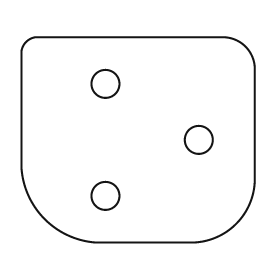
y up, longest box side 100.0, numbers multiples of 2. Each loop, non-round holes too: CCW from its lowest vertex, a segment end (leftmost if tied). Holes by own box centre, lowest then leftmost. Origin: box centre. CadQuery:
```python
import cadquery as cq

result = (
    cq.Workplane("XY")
    .moveTo(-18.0, -44.0)
    .lineTo(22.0, -44.0)
    .threePointArc((42.0, -36.0), (50.0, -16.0))
    .lineTo(50.0, 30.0)
    .threePointArc((46.0, 40.0), (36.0, 44.0))
    .lineTo(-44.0, 44.0)
    .threePointArc((-48.0, 42.0), (-50.0, 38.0))
    .lineTo(-50.0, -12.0)
    .threePointArc((-40.0, -34.0), (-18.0, -44.0))
    .close()
    .moveTo(-14.0, -24.0)
    .circle(6.0)
    .moveTo(26.0, 0.0)
    .circle(6.0)
    .moveTo(-14.0, 24.0)
    .circle(6.0)
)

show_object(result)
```